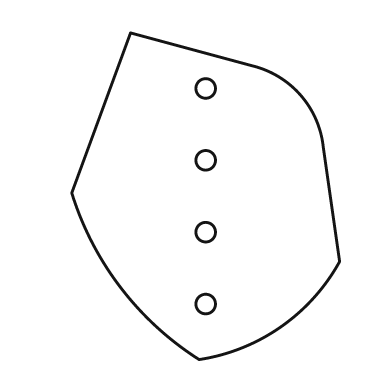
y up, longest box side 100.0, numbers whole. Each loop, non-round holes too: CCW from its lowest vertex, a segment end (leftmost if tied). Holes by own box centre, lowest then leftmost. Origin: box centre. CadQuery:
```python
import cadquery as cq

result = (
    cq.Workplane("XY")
    .moveTo(-2.0, -50.0)
    .threePointArc((23.0, -40.0), (41.0, -20.0))
    .lineTo(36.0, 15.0)
    .threePointArc((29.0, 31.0), (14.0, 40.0))
    .lineTo(-23.0, 50.0)
    .lineTo(-41.0, 1.0)
    .threePointArc((-26.0, -28.0), (-2.0, -50.0))
    .close()
    .moveTo(0.0, -33.0)
    .circle(3.0)
    .moveTo(0.0, -11.0)
    .circle(3.0)
    .moveTo(0.0, 11.0)
    .circle(3.0)
    .moveTo(0.0, 33.0)
    .circle(3.0)
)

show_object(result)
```